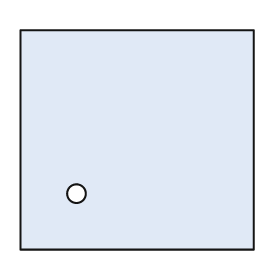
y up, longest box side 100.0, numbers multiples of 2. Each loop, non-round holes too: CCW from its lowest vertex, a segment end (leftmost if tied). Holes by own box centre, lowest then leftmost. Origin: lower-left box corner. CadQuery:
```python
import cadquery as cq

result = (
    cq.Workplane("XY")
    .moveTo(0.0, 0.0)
    .lineTo(100.0, 0.0)
    .lineTo(100.0, 94.0)
    .lineTo(0.0, 94.0)
    .close()
    .moveTo(24.0, 24.0)
    .circle(4.0)
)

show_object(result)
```